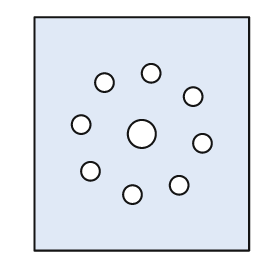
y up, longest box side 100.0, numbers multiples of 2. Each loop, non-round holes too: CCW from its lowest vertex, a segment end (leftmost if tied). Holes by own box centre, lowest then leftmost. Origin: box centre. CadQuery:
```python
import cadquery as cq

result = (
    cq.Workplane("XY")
    .moveTo(-46.0, -50.0)
    .lineTo(46.0, -50.0)
    .lineTo(46.0, 50.0)
    .lineTo(-46.0, 50.0)
    .close()
    .moveTo(-4.0, -26.0)
    .circle(4.0)
    .moveTo(16.0, -22.0)
    .circle(4.0)
    .moveTo(-22.0, -16.0)
    .circle(4.0)
    .moveTo(26.0, -4.0)
    .circle(4.0)
    .moveTo(0.0, 0.0)
    .circle(6.0)
    .moveTo(-26.0, 4.0)
    .circle(4.0)
    .moveTo(22.0, 16.0)
    .circle(4.0)
    .moveTo(-16.0, 22.0)
    .circle(4.0)
    .moveTo(4.0, 26.0)
    .circle(4.0)
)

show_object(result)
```